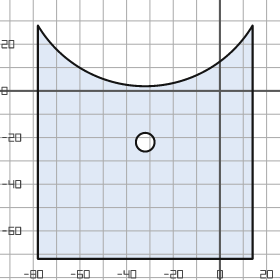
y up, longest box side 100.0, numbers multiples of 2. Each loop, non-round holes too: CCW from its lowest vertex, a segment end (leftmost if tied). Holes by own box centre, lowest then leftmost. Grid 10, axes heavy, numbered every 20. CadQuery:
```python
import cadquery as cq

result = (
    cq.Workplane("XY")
    .moveTo(-78.0, -72.0)
    .lineTo(14.0, -72.0)
    .lineTo(14.0, 28.0)
    .threePointArc((-32.0, 2.0), (-78.0, 28.0))
    .close()
    .moveTo(-32.0, -22.0)
    .circle(4.0)
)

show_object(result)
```